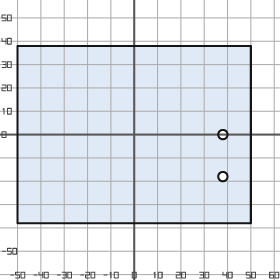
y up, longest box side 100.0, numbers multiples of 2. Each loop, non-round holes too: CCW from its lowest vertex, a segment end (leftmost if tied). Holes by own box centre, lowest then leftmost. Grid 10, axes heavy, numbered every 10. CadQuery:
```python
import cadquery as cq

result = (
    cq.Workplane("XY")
    .moveTo(-50.0, -38.0)
    .lineTo(50.0, -38.0)
    .lineTo(50.0, 38.0)
    .lineTo(-50.0, 38.0)
    .close()
    .moveTo(38.0, -18.0)
    .circle(2.0)
    .moveTo(38.0, 0.0)
    .circle(2.0)
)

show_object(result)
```